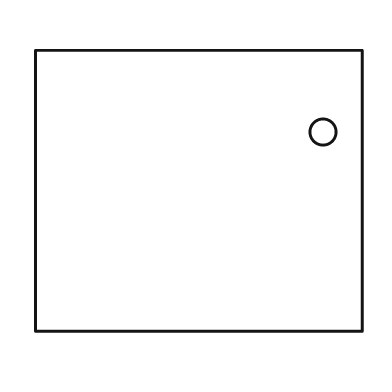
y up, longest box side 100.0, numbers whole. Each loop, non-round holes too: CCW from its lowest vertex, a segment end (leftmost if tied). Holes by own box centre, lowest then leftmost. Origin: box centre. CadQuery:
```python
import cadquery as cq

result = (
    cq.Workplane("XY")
    .moveTo(-50.0, -43.0)
    .lineTo(50.0, -43.0)
    .lineTo(50.0, 43.0)
    .lineTo(-50.0, 43.0)
    .close()
    .moveTo(38.0, 18.0)
    .circle(4.0)
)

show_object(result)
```